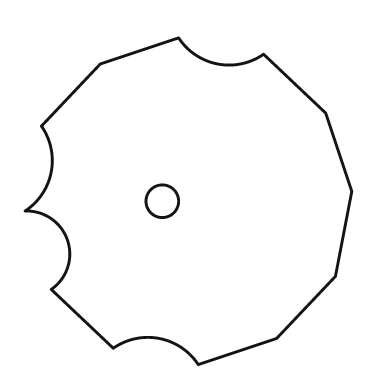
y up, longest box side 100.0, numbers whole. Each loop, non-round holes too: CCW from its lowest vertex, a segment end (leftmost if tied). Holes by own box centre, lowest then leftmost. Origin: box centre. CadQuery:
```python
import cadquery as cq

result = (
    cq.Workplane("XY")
    .moveTo(3.0, -50.0)
    .lineTo(27.0, -42.0)
    .lineTo(45.0, -23.0)
    .lineTo(50.0, 3.0)
    .lineTo(42.0, 27.0)
    .lineTo(23.0, 45.0)
    .threePointArc((9.0, 42.0), (-3.0, 50.0))
    .lineTo(-27.0, 42.0)
    .lineTo(-45.0, 23.0)
    .threePointArc((-42.0, 9.0), (-50.0, -3.0))
    .threePointArc((-37.0, -12.0), (-42.0, -27.0))
    .lineTo(-23.0, -45.0)
    .threePointArc((-9.0, -42.0), (3.0, -50.0))
    .close()
    .moveTo(-8.0, 0.0)
    .circle(5.0)
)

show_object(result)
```